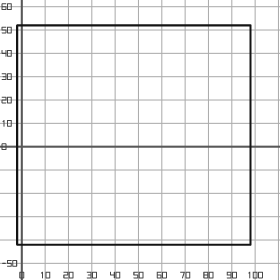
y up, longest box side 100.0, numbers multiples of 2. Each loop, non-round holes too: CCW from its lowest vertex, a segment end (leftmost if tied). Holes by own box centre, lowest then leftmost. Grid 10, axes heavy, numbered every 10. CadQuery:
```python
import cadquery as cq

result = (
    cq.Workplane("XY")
    .moveTo(-2.0, -42.0)
    .lineTo(98.0, -42.0)
    .lineTo(98.0, 52.0)
    .lineTo(-2.0, 52.0)
    .close()
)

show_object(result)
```